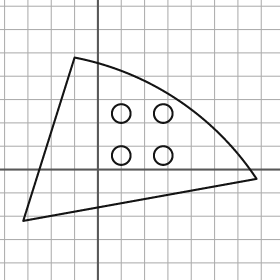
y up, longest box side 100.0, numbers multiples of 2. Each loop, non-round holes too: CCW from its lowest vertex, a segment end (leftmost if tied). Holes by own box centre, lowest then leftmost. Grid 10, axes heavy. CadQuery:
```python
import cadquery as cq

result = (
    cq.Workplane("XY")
    .moveTo(-32.0, -22.0)
    .lineTo(68.0, -4.0)
    .threePointArc((34.0, 30.0), (-10.0, 48.0))
    .close()
    .moveTo(10.0, 6.0)
    .circle(4.0)
    .moveTo(28.0, 6.0)
    .circle(4.0)
    .moveTo(10.0, 24.0)
    .circle(4.0)
    .moveTo(28.0, 24.0)
    .circle(4.0)
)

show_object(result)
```